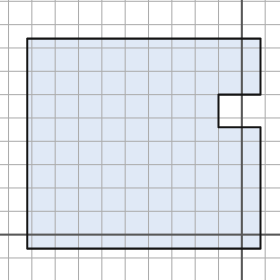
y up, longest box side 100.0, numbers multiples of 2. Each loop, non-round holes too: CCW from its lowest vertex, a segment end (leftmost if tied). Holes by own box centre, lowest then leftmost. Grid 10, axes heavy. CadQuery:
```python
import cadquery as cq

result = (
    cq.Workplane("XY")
    .moveTo(-92.0, -6.0)
    .lineTo(8.0, -6.0)
    .lineTo(8.0, 46.0)
    .lineTo(-10.0, 46.0)
    .lineTo(-10.0, 60.0)
    .lineTo(8.0, 60.0)
    .lineTo(8.0, 84.0)
    .lineTo(-92.0, 84.0)
    .close()
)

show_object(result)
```